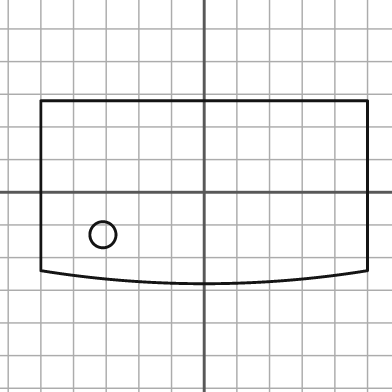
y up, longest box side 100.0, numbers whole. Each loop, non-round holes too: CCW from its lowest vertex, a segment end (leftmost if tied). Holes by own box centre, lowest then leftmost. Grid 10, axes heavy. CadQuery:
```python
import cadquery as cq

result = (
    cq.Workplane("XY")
    .moveTo(-50.0, -24.0)
    .threePointArc((0.0, -28.0), (50.0, -24.0))
    .lineTo(50.0, 28.0)
    .lineTo(-50.0, 28.0)
    .close()
    .moveTo(-31.0, -13.0)
    .circle(4.0)
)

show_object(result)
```